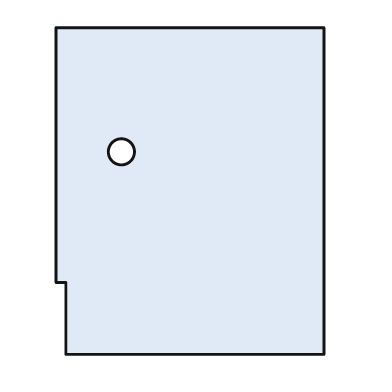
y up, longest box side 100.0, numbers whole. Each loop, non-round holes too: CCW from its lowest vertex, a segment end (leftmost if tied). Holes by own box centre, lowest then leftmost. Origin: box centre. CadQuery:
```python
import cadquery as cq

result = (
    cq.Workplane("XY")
    .moveTo(-38.0, -50.0)
    .lineTo(41.0, -50.0)
    .lineTo(41.0, 50.0)
    .lineTo(-41.0, 50.0)
    .lineTo(-41.0, -28.0)
    .lineTo(-38.0, -28.0)
    .close()
    .moveTo(-21.0, 12.0)
    .circle(4.0)
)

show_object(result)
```